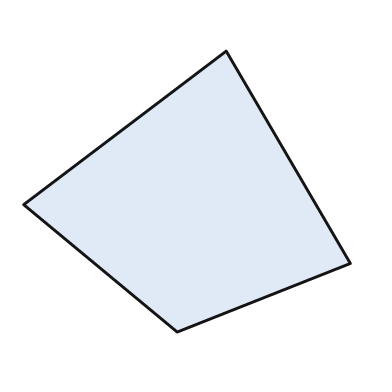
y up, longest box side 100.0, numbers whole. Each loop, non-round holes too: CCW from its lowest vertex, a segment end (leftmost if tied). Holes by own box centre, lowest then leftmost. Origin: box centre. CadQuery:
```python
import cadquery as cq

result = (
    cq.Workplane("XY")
    .moveTo(-3.0, -43.0)
    .lineTo(50.0, -22.0)
    .lineTo(12.0, 43.0)
    .lineTo(-50.0, -4.0)
    .close()
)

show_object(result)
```